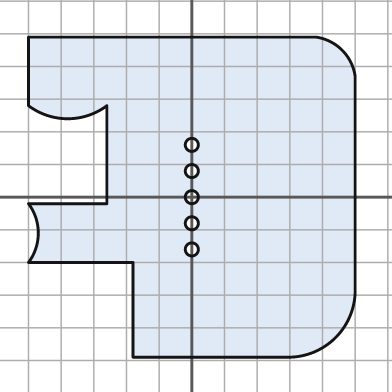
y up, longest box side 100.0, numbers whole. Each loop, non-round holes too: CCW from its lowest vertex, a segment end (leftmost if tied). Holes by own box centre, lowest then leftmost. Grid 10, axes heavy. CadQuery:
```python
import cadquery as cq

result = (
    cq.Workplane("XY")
    .moveTo(-18.0, -49.0)
    .lineTo(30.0, -49.0)
    .threePointArc((44.0, -43.0), (50.0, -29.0))
    .lineTo(50.0, 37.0)
    .threePointArc((46.0, 45.0), (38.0, 49.0))
    .lineTo(-50.0, 49.0)
    .lineTo(-50.0, 28.0)
    .threePointArc((-38.0, 24.0), (-26.0, 28.0))
    .lineTo(-26.0, -2.0)
    .lineTo(-50.0, -2.0)
    .threePointArc((-47.0, -11.0), (-50.0, -20.0))
    .lineTo(-18.0, -20.0)
    .close()
    .moveTo(0.0, -16.0)
    .circle(2.0)
    .moveTo(0.0, -8.0)
    .circle(2.0)
    .moveTo(0.0, 0.0)
    .circle(2.0)
    .moveTo(0.0, 8.0)
    .circle(2.0)
    .moveTo(0.0, 16.0)
    .circle(2.0)
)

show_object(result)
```